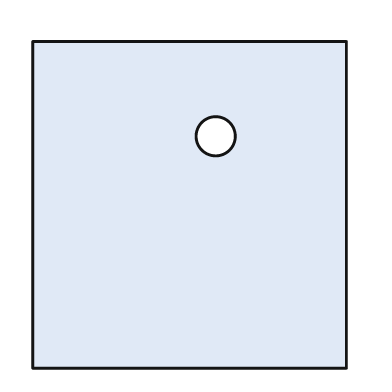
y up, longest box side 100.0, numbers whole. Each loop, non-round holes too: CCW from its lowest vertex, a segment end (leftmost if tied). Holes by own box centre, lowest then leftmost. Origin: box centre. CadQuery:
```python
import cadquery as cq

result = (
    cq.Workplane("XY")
    .moveTo(-48.0, -50.0)
    .lineTo(48.0, -50.0)
    .lineTo(48.0, 50.0)
    .lineTo(-48.0, 50.0)
    .close()
    .moveTo(8.0, 21.0)
    .circle(6.0)
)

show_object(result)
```